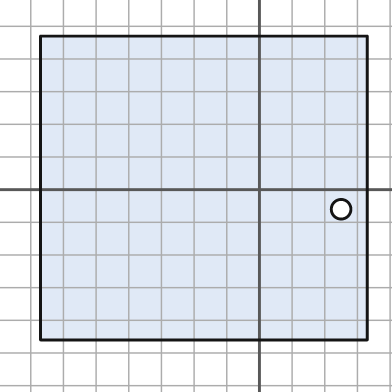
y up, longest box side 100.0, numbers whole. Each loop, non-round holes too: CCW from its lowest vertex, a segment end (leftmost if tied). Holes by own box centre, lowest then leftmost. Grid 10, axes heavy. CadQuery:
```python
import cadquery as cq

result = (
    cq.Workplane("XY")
    .moveTo(-67.0, -46.0)
    .lineTo(33.0, -46.0)
    .lineTo(33.0, 47.0)
    .lineTo(-67.0, 47.0)
    .close()
    .moveTo(25.0, -6.0)
    .circle(3.0)
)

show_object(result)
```